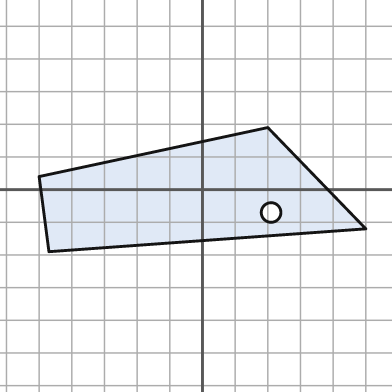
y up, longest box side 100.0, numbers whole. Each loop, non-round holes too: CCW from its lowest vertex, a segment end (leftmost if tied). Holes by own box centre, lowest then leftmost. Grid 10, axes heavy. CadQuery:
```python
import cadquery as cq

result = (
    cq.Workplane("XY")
    .moveTo(-47.0, -19.0)
    .lineTo(50.0, -12.0)
    .lineTo(20.0, 19.0)
    .lineTo(-50.0, 4.0)
    .close()
    .moveTo(21.0, -7.0)
    .circle(3.0)
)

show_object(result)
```